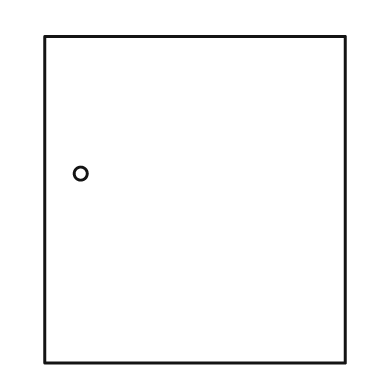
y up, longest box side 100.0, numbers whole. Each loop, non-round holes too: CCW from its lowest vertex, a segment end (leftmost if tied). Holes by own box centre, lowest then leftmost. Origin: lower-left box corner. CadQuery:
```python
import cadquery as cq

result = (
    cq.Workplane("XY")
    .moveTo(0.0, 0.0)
    .lineTo(92.0, 0.0)
    .lineTo(92.0, 100.0)
    .lineTo(0.0, 100.0)
    .close()
    .moveTo(11.0, 58.0)
    .circle(2.0)
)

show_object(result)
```